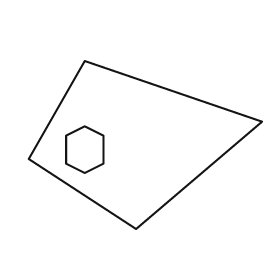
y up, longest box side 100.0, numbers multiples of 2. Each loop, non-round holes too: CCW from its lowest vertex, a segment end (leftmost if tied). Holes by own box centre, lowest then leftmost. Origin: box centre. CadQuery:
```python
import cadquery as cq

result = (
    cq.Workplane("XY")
    .moveTo(-4.0, -36.0)
    .lineTo(50.0, 10.0)
    .lineTo(-26.0, 36.0)
    .lineTo(-50.0, -6.0)
    .close()
    .moveTo(-26.0, -12.0)
    .lineTo(-18.0, -8.0)
    .lineTo(-18.0, 4.0)
    .lineTo(-26.0, 8.0)
    .lineTo(-34.0, 4.0)
    .lineTo(-34.0, -8.0)
    .close()
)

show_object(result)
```